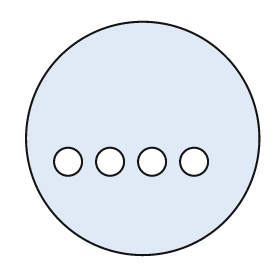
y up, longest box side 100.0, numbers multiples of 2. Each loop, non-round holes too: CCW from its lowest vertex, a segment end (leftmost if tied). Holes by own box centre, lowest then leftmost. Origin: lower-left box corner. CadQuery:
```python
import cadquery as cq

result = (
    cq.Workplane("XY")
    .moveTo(50.0, 50.0)
    .circle(50.0)
    .moveTo(18.0, 40.0)
    .circle(6.0)
    .moveTo(36.0, 40.0)
    .circle(6.0)
    .moveTo(54.0, 40.0)
    .circle(6.0)
    .moveTo(72.0, 40.0)
    .circle(6.0)
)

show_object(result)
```